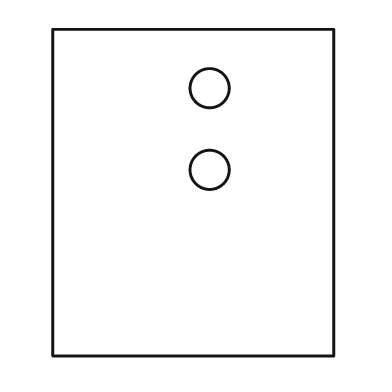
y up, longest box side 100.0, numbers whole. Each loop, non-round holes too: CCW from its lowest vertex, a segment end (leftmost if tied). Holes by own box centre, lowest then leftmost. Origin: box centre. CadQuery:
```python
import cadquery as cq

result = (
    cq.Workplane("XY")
    .moveTo(-43.0, -50.0)
    .lineTo(43.0, -50.0)
    .lineTo(43.0, 50.0)
    .lineTo(-43.0, 50.0)
    .close()
    .moveTo(5.0, 7.0)
    .circle(6.0)
    .moveTo(5.0, 32.0)
    .circle(6.0)
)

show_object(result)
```